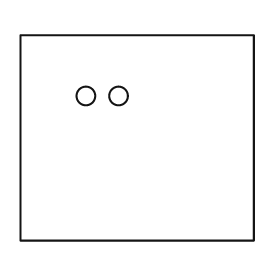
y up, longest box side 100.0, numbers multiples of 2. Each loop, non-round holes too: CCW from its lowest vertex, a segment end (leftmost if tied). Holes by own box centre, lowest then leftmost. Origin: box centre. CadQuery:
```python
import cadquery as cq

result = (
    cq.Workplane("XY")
    .moveTo(-50.0, -44.0)
    .lineTo(50.0, -44.0)
    .lineTo(50.0, 44.0)
    .lineTo(-50.0, 44.0)
    .close()
    .moveTo(-22.0, 18.0)
    .circle(4.0)
    .moveTo(-8.0, 18.0)
    .circle(4.0)
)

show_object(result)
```